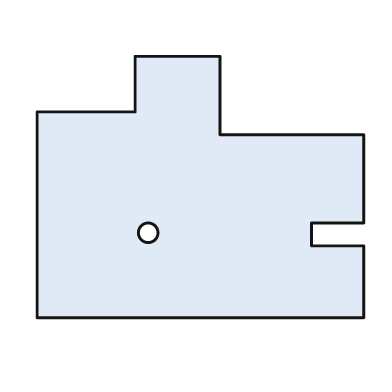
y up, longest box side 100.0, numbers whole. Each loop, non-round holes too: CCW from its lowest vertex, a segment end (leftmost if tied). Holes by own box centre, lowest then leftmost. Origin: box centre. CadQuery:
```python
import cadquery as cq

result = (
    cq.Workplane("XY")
    .moveTo(-50.0, -40.0)
    .lineTo(50.0, -40.0)
    .lineTo(50.0, -18.0)
    .lineTo(34.0, -18.0)
    .lineTo(34.0, -11.0)
    .lineTo(50.0, -11.0)
    .lineTo(50.0, 16.0)
    .lineTo(6.0, 16.0)
    .lineTo(6.0, 40.0)
    .lineTo(-20.0, 40.0)
    .lineTo(-20.0, 23.0)
    .lineTo(-50.0, 23.0)
    .close()
    .moveTo(-16.0, -14.0)
    .circle(3.0)
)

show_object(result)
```